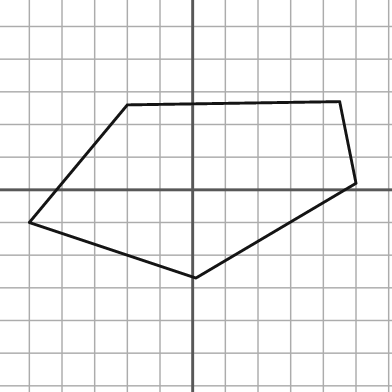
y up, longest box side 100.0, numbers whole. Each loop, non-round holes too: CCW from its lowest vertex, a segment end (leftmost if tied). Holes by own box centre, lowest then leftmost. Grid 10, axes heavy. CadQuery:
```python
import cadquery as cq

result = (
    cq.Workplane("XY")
    .moveTo(1.0, -27.0)
    .lineTo(50.0, 2.0)
    .lineTo(45.0, 27.0)
    .lineTo(-20.0, 26.0)
    .lineTo(-50.0, -10.0)
    .close()
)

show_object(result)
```